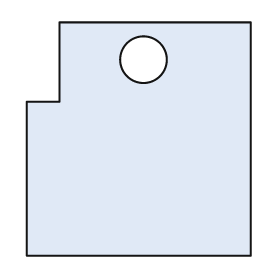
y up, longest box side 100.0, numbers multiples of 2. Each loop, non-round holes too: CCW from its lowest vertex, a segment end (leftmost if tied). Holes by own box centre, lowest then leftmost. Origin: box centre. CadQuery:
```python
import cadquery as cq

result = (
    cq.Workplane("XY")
    .moveTo(-48.0, -50.0)
    .lineTo(48.0, -50.0)
    .lineTo(48.0, 50.0)
    .lineTo(-34.0, 50.0)
    .lineTo(-34.0, 16.0)
    .lineTo(-48.0, 16.0)
    .close()
    .moveTo(2.0, 34.0)
    .circle(10.0)
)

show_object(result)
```